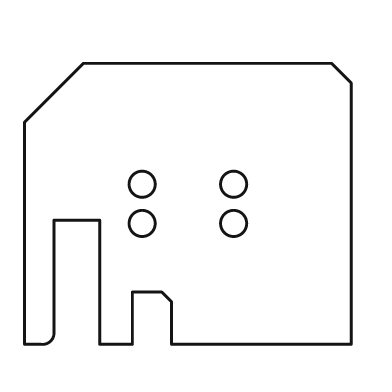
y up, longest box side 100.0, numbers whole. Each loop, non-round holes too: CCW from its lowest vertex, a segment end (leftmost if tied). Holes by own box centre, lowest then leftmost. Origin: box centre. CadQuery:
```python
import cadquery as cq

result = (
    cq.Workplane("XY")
    .moveTo(-50.0, -43.0)
    .lineTo(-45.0, -43.0)
    .threePointArc((-42.0, -42.0), (-41.0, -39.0))
    .lineTo(-41.0, -5.0)
    .lineTo(-27.0, -5.0)
    .lineTo(-27.0, -43.0)
    .lineTo(-17.0, -43.0)
    .lineTo(-17.0, -27.0)
    .lineTo(-8.0, -27.0)
    .lineTo(-5.0, -30.0)
    .lineTo(-5.0, -43.0)
    .lineTo(50.0, -43.0)
    .lineTo(50.0, 37.0)
    .lineTo(44.0, 43.0)
    .lineTo(-32.0, 43.0)
    .lineTo(-50.0, 25.0)
    .close()
    .moveTo(-14.0, -6.0)
    .circle(4.0)
    .moveTo(14.0, -6.0)
    .circle(4.0)
    .moveTo(-14.0, 6.0)
    .circle(4.0)
    .moveTo(14.0, 6.0)
    .circle(4.0)
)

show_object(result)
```